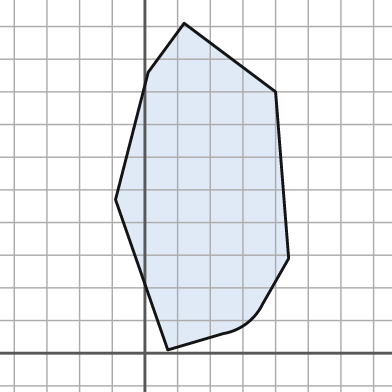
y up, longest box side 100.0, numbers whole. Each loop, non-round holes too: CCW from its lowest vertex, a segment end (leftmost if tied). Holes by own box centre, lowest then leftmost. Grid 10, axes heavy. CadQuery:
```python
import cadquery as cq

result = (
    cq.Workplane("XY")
    .moveTo(7.0, 1.0)
    .lineTo(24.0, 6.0)
    .threePointArc((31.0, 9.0), (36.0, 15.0))
    .lineTo(44.0, 29.0)
    .lineTo(40.0, 80.0)
    .lineTo(12.0, 101.0)
    .lineTo(1.0, 86.0)
    .lineTo(-9.0, 47.0)
    .close()
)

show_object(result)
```